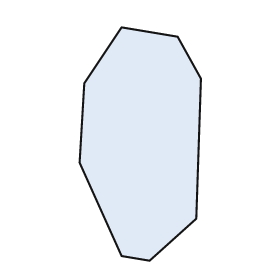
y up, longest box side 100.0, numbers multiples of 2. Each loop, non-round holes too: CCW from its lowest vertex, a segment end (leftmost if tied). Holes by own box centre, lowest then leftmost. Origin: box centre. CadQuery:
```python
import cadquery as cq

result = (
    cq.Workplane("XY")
    .moveTo(4.0, -50.0)
    .lineTo(24.0, -32.0)
    .lineTo(26.0, 28.0)
    .lineTo(16.0, 46.0)
    .lineTo(-8.0, 50.0)
    .lineTo(-24.0, 26.0)
    .lineTo(-26.0, -8.0)
    .lineTo(-8.0, -48.0)
    .close()
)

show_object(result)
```